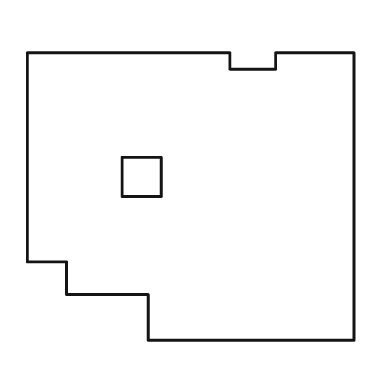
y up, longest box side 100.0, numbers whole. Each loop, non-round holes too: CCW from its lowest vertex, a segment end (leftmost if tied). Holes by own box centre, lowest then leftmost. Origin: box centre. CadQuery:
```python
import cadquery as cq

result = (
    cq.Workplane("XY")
    .moveTo(-13.0, -44.0)
    .lineTo(50.0, -44.0)
    .lineTo(50.0, 44.0)
    .lineTo(26.0, 44.0)
    .lineTo(26.0, 39.0)
    .lineTo(12.0, 39.0)
    .lineTo(12.0, 44.0)
    .lineTo(-50.0, 44.0)
    .lineTo(-50.0, -20.0)
    .lineTo(-38.0, -20.0)
    .lineTo(-38.0, -30.0)
    .lineTo(-13.0, -30.0)
    .close()
    .moveTo(-21.0, 0.0)
    .lineTo(-9.0, 0.0)
    .lineTo(-9.0, 12.0)
    .lineTo(-21.0, 12.0)
    .close()
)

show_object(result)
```